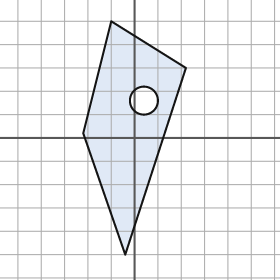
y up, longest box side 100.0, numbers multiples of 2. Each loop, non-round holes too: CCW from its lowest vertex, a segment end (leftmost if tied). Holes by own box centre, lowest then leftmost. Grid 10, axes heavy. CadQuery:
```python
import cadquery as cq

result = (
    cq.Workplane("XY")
    .moveTo(-4.0, -50.0)
    .lineTo(22.0, 30.0)
    .lineTo(-10.0, 50.0)
    .lineTo(-22.0, 2.0)
    .close()
    .moveTo(4.0, 16.0)
    .circle(6.0)
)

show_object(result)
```